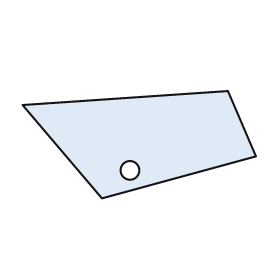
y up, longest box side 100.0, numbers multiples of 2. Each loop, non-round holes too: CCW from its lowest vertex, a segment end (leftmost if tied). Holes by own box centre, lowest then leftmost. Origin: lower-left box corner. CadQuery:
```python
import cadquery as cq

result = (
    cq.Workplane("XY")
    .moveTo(34.0, 0.0)
    .lineTo(100.0, 18.0)
    .lineTo(88.0, 46.0)
    .lineTo(0.0, 40.0)
    .close()
    .moveTo(46.0, 12.0)
    .circle(4.0)
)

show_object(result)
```